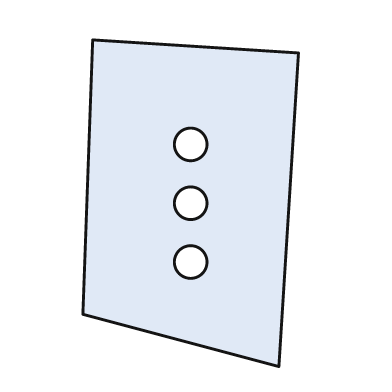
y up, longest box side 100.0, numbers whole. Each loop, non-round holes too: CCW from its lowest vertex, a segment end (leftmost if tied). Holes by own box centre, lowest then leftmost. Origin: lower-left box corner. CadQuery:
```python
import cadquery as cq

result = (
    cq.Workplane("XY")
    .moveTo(60.0, 0.0)
    .lineTo(66.0, 96.0)
    .lineTo(3.0, 100.0)
    .lineTo(0.0, 16.0)
    .close()
    .moveTo(33.0, 32.0)
    .circle(5.0)
    .moveTo(33.0, 50.0)
    .circle(5.0)
    .moveTo(33.0, 68.0)
    .circle(5.0)
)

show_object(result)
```